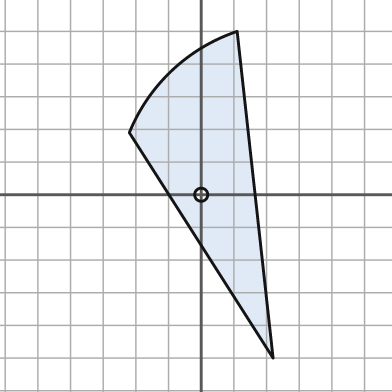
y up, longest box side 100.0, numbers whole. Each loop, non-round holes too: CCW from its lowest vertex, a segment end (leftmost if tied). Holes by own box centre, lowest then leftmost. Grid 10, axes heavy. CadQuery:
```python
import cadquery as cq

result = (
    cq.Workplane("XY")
    .moveTo(22.0, -50.0)
    .lineTo(11.0, 50.0)
    .threePointArc((-9.0, 38.0), (-22.0, 19.0))
    .close()
    .moveTo(0.0, 0.0)
    .circle(2.0)
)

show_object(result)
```